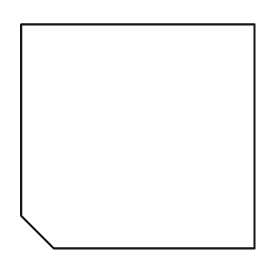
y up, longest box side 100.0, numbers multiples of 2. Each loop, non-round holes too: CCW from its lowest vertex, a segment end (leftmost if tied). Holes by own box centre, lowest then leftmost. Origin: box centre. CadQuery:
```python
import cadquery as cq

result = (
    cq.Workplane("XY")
    .moveTo(-36.0, -48.0)
    .lineTo(50.0, -48.0)
    .lineTo(50.0, 48.0)
    .lineTo(-50.0, 48.0)
    .lineTo(-50.0, -34.0)
    .close()
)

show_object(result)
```